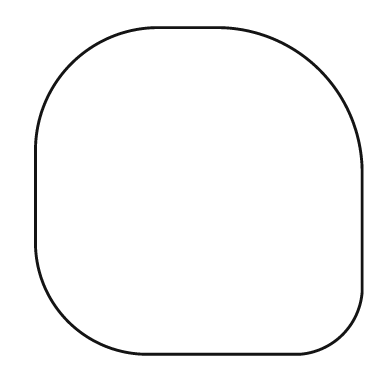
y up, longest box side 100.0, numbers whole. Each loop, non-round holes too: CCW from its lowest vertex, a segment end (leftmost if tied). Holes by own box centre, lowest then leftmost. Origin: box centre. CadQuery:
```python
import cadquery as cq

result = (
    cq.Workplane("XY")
    .moveTo(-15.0, -50.0)
    .lineTo(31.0, -50.0)
    .threePointArc((44.0, -44.0), (50.0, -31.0))
    .lineTo(50.0, 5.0)
    .threePointArc((37.0, 37.0), (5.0, 50.0))
    .lineTo(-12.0, 50.0)
    .threePointArc((-39.0, 39.0), (-50.0, 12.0))
    .lineTo(-50.0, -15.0)
    .threePointArc((-40.0, -40.0), (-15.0, -50.0))
    .close()
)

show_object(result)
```